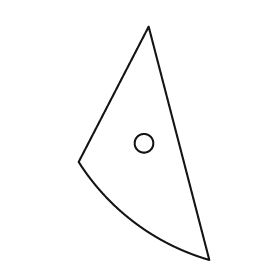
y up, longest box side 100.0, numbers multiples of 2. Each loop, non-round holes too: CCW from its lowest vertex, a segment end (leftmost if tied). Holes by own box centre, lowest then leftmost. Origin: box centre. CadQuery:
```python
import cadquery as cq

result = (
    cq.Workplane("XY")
    .moveTo(28.0, -50.0)
    .lineTo(2.0, 50.0)
    .lineTo(-28.0, -8.0)
    .threePointArc((-4.0, -34.0), (28.0, -50.0))
    .close()
    .moveTo(0.0, 0.0)
    .circle(4.0)
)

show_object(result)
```